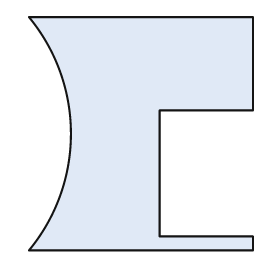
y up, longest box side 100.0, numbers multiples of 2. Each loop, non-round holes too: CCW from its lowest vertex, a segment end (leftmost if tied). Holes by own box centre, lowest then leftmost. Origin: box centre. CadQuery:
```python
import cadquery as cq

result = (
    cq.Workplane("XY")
    .moveTo(-48.0, -50.0)
    .lineTo(48.0, -50.0)
    .lineTo(48.0, -44.0)
    .lineTo(8.0, -44.0)
    .lineTo(8.0, 10.0)
    .lineTo(48.0, 10.0)
    .lineTo(48.0, 50.0)
    .lineTo(-48.0, 50.0)
    .threePointArc((-30.0, 0.0), (-48.0, -50.0))
    .close()
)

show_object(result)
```